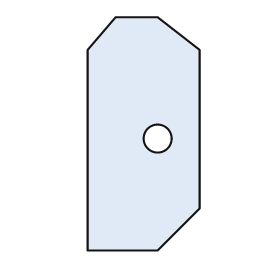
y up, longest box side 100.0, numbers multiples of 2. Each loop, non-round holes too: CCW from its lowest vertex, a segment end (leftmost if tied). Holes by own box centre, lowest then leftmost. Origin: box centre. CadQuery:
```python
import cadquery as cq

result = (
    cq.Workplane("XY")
    .moveTo(-24.0, -50.0)
    .lineTo(6.0, -50.0)
    .lineTo(24.0, -32.0)
    .lineTo(24.0, 36.0)
    .lineTo(6.0, 50.0)
    .lineTo(-12.0, 50.0)
    .lineTo(-24.0, 36.0)
    .close()
    .moveTo(6.0, -2.0)
    .circle(6.0)
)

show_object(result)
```